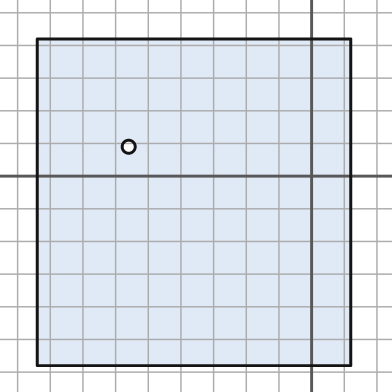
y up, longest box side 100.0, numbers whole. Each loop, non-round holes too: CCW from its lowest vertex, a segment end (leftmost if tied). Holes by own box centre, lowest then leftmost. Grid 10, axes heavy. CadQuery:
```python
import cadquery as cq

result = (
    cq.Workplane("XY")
    .moveTo(-84.0, -58.0)
    .lineTo(12.0, -58.0)
    .lineTo(12.0, 42.0)
    .lineTo(-84.0, 42.0)
    .close()
    .moveTo(-56.0, 9.0)
    .circle(2.0)
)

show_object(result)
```